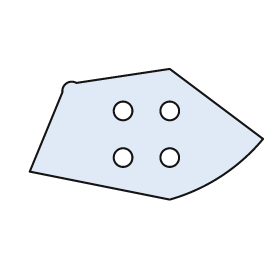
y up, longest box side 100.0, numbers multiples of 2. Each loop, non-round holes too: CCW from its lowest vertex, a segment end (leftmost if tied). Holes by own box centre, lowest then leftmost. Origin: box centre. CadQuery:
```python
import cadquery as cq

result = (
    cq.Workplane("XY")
    .moveTo(10.0, -28.0)
    .threePointArc((32.0, -18.0), (50.0, -2.0))
    .lineTo(10.0, 28.0)
    .lineTo(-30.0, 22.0)
    .threePointArc((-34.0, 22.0), (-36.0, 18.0))
    .lineTo(-50.0, -16.0)
    .close()
    .moveTo(-10.0, -10.0)
    .circle(4.0)
    .moveTo(10.0, -10.0)
    .circle(4.0)
    .moveTo(-10.0, 10.0)
    .circle(4.0)
    .moveTo(10.0, 10.0)
    .circle(4.0)
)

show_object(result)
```